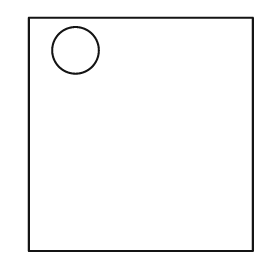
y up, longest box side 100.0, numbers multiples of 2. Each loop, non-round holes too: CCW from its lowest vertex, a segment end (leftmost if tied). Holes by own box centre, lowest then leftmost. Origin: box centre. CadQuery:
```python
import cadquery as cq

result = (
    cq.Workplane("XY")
    .moveTo(-48.0, -50.0)
    .lineTo(48.0, -50.0)
    .lineTo(48.0, 50.0)
    .lineTo(-48.0, 50.0)
    .close()
    .moveTo(-28.0, 36.0)
    .circle(10.0)
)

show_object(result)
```